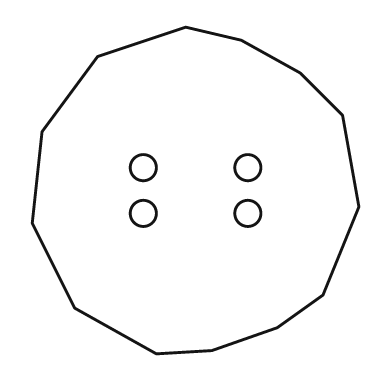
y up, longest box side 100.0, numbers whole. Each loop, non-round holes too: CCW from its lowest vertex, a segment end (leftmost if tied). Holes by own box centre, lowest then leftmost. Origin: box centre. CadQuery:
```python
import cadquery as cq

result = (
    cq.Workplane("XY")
    .moveTo(-12.0, -50.0)
    .lineTo(5.0, -49.0)
    .lineTo(25.0, -42.0)
    .lineTo(39.0, -32.0)
    .lineTo(50.0, -5.0)
    .lineTo(45.0, 23.0)
    .lineTo(32.0, 36.0)
    .lineTo(14.0, 46.0)
    .lineTo(-3.0, 50.0)
    .lineTo(-30.0, 41.0)
    .lineTo(-47.0, 18.0)
    .lineTo(-50.0, -10.0)
    .lineTo(-37.0, -36.0)
    .close()
    .moveTo(-16.0, -7.0)
    .circle(4.0)
    .moveTo(16.0, -7.0)
    .circle(4.0)
    .moveTo(-16.0, 7.0)
    .circle(4.0)
    .moveTo(16.0, 7.0)
    .circle(4.0)
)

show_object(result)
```